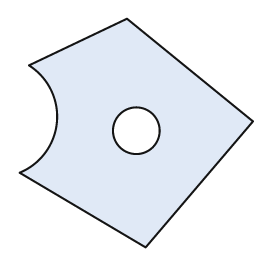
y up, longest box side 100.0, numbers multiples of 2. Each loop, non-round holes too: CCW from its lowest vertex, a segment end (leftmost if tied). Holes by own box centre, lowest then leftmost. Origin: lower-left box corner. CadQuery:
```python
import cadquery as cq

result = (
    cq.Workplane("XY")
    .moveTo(54.0, 0.0)
    .lineTo(100.0, 54.0)
    .lineTo(46.0, 98.0)
    .lineTo(4.0, 78.0)
    .threePointArc((16.0, 54.0), (0.0, 32.0))
    .close()
    .moveTo(50.0, 50.0)
    .circle(10.0)
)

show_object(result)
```